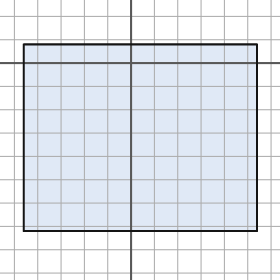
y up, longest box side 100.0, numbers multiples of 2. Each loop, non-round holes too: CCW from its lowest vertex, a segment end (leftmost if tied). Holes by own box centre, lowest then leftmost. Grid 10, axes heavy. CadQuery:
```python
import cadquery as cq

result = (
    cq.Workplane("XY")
    .moveTo(-46.0, -72.0)
    .lineTo(54.0, -72.0)
    .lineTo(54.0, 8.0)
    .lineTo(-46.0, 8.0)
    .close()
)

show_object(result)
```